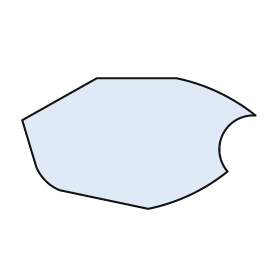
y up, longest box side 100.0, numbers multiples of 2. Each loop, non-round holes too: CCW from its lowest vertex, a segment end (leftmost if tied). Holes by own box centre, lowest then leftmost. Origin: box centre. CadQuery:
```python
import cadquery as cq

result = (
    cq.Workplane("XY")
    .moveTo(4.0, -28.0)
    .threePointArc((22.0, -22.0), (38.0, -12.0))
    .threePointArc((36.0, 4.0), (50.0, 12.0))
    .threePointArc((34.0, 22.0), (16.0, 28.0))
    .lineTo(-18.0, 28.0)
    .lineTo(-50.0, 10.0)
    .lineTo(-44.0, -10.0)
    .threePointArc((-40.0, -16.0), (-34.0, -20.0))
    .close()
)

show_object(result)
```